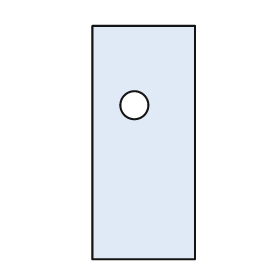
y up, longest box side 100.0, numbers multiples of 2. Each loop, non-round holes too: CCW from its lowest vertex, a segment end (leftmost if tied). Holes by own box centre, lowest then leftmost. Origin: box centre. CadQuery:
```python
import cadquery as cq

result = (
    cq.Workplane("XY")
    .moveTo(-22.0, -50.0)
    .lineTo(22.0, -50.0)
    .lineTo(22.0, 50.0)
    .lineTo(-22.0, 50.0)
    .close()
    .moveTo(-4.0, 16.0)
    .circle(6.0)
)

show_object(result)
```